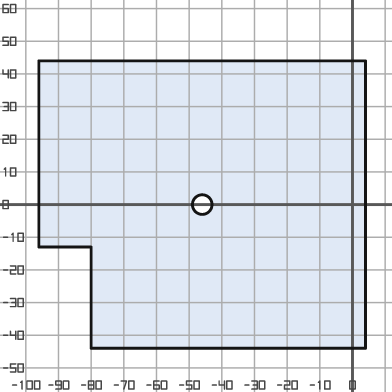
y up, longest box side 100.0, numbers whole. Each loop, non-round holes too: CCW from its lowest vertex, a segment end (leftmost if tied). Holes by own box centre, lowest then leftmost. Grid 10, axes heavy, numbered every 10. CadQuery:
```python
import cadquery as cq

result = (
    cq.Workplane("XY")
    .moveTo(-80.0, -44.0)
    .lineTo(4.0, -44.0)
    .lineTo(4.0, 44.0)
    .lineTo(-96.0, 44.0)
    .lineTo(-96.0, -13.0)
    .lineTo(-80.0, -13.0)
    .close()
    .moveTo(-46.0, 0.0)
    .circle(3.0)
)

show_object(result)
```